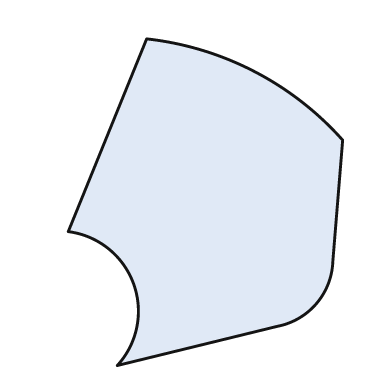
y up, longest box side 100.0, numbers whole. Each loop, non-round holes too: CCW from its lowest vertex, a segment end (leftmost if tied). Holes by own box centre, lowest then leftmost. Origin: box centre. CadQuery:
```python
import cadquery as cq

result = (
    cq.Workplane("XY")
    .moveTo(-27.0, -50.0)
    .lineTo(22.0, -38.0)
    .threePointArc((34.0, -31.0), (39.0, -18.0))
    .lineTo(42.0, 19.0)
    .threePointArc((15.0, 40.0), (-18.0, 50.0))
    .lineTo(-42.0, -9.0)
    .threePointArc((-22.0, -25.0), (-27.0, -50.0))
    .close()
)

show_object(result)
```